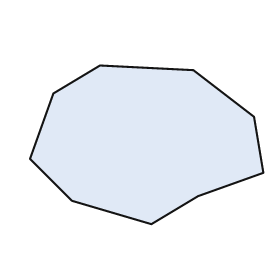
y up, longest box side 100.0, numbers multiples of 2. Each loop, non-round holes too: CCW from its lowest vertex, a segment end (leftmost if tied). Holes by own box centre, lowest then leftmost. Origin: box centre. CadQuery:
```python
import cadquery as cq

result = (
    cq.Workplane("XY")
    .moveTo(2.0, -34.0)
    .lineTo(22.0, -22.0)
    .lineTo(50.0, -12.0)
    .lineTo(46.0, 12.0)
    .lineTo(20.0, 32.0)
    .lineTo(-20.0, 34.0)
    .lineTo(-40.0, 22.0)
    .lineTo(-50.0, -6.0)
    .lineTo(-32.0, -24.0)
    .close()
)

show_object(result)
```